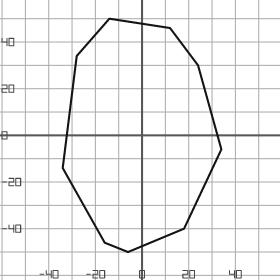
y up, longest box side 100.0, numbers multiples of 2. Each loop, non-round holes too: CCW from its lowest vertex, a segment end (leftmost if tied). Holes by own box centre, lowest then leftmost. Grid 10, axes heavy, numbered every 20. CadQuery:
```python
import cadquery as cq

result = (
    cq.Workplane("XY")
    .moveTo(-6.0, -50.0)
    .lineTo(18.0, -40.0)
    .lineTo(34.0, -6.0)
    .lineTo(24.0, 30.0)
    .lineTo(12.0, 46.0)
    .lineTo(-14.0, 50.0)
    .lineTo(-28.0, 34.0)
    .lineTo(-34.0, -14.0)
    .lineTo(-16.0, -46.0)
    .close()
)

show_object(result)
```